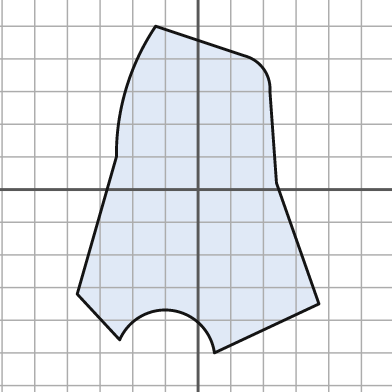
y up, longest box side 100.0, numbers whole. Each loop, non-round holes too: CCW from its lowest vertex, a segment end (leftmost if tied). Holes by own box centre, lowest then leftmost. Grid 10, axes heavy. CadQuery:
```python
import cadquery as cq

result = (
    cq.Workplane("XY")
    .moveTo(5.0, -50.0)
    .lineTo(37.0, -35.0)
    .lineTo(24.0, 2.0)
    .lineTo(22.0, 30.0)
    .threePointArc((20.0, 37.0), (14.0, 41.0))
    .lineTo(-13.0, 50.0)
    .threePointArc((-22.0, 31.0), (-25.0, 10.0))
    .lineTo(-37.0, -32.0)
    .lineTo(-24.0, -46.0)
    .threePointArc((-8.0, -37.0), (5.0, -50.0))
    .close()
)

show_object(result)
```